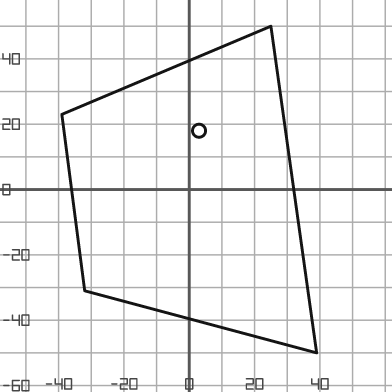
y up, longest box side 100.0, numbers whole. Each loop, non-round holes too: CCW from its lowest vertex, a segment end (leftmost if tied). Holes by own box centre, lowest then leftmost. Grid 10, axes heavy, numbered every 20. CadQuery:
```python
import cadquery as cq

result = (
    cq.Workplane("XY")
    .moveTo(39.0, -50.0)
    .lineTo(25.0, 50.0)
    .lineTo(-39.0, 23.0)
    .lineTo(-32.0, -31.0)
    .close()
    .moveTo(3.0, 18.0)
    .circle(2.0)
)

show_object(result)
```